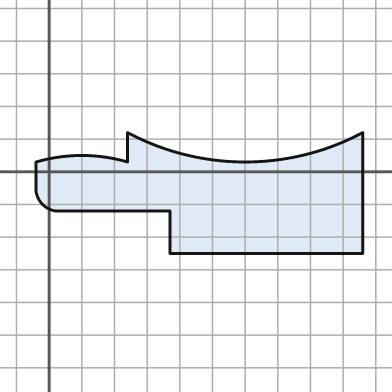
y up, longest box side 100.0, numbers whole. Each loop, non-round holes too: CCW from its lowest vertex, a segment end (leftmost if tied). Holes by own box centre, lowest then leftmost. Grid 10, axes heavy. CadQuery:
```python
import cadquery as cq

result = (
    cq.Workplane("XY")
    .moveTo(37.0, -25.0)
    .lineTo(96.0, -25.0)
    .lineTo(96.0, 12.0)
    .threePointArc((60.0, 3.0), (24.0, 12.0))
    .lineTo(24.0, 3.0)
    .threePointArc((10.0, 5.0), (-4.0, 3.0))
    .lineTo(-4.0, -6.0)
    .threePointArc((-2.0, -10.0), (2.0, -12.0))
    .lineTo(37.0, -12.0)
    .close()
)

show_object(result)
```